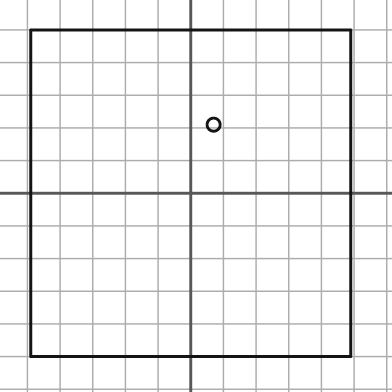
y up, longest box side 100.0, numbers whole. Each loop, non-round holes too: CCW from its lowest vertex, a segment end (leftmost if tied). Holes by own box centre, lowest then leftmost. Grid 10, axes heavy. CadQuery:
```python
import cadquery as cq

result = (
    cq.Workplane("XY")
    .moveTo(-49.0, -50.0)
    .lineTo(49.0, -50.0)
    .lineTo(49.0, 50.0)
    .lineTo(-49.0, 50.0)
    .close()
    .moveTo(7.0, 21.0)
    .circle(2.0)
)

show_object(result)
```